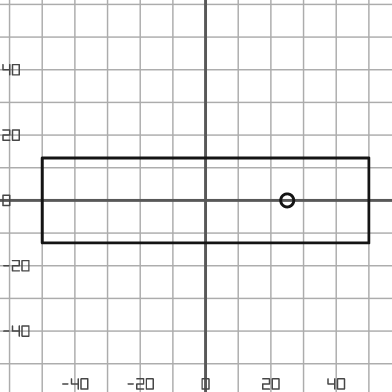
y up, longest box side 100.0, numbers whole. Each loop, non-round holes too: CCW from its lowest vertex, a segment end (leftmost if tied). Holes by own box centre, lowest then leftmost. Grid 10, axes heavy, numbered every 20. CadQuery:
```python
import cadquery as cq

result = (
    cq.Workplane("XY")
    .moveTo(-50.0, -13.0)
    .lineTo(50.0, -13.0)
    .lineTo(50.0, 13.0)
    .lineTo(-50.0, 13.0)
    .close()
    .moveTo(25.0, 0.0)
    .circle(2.0)
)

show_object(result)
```